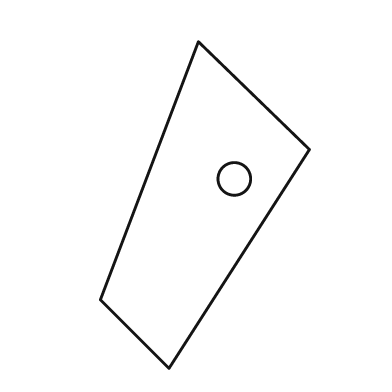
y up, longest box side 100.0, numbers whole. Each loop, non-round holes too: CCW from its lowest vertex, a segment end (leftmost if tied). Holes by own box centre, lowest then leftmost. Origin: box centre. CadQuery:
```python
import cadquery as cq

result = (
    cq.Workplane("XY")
    .moveTo(-11.0, -50.0)
    .lineTo(32.0, 17.0)
    .lineTo(-2.0, 50.0)
    .lineTo(-32.0, -29.0)
    .close()
    .moveTo(9.0, 8.0)
    .circle(5.0)
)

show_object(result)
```